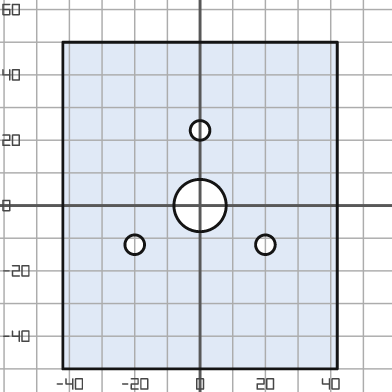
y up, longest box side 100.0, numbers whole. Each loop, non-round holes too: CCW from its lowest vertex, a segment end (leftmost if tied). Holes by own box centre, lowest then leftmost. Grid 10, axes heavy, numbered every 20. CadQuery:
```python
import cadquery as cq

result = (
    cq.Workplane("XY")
    .moveTo(-42.0, -50.0)
    .lineTo(42.0, -50.0)
    .lineTo(42.0, 50.0)
    .lineTo(-42.0, 50.0)
    .close()
    .moveTo(-20.0, -12.0)
    .circle(3.0)
    .moveTo(20.0, -12.0)
    .circle(3.0)
    .moveTo(0.0, 0.0)
    .circle(8.0)
    .moveTo(0.0, 23.0)
    .circle(3.0)
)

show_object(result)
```